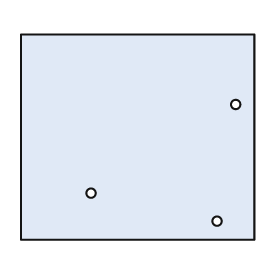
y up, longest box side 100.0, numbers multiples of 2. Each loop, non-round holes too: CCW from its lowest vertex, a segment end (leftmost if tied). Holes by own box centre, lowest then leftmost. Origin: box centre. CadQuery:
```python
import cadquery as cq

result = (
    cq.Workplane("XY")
    .moveTo(-50.0, -44.0)
    .lineTo(50.0, -44.0)
    .lineTo(50.0, 44.0)
    .lineTo(-50.0, 44.0)
    .close()
    .moveTo(34.0, -36.0)
    .circle(2.0)
    .moveTo(-20.0, -24.0)
    .circle(2.0)
    .moveTo(42.0, 14.0)
    .circle(2.0)
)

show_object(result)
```